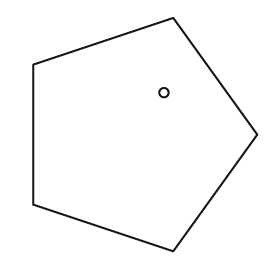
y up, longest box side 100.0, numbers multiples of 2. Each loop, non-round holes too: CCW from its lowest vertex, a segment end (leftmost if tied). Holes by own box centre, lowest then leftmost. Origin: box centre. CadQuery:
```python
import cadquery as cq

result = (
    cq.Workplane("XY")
    .moveTo(12.0, -50.0)
    .lineTo(48.0, 0.0)
    .lineTo(12.0, 50.0)
    .lineTo(-48.0, 30.0)
    .lineTo(-48.0, -30.0)
    .close()
    .moveTo(8.0, 18.0)
    .circle(2.0)
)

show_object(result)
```